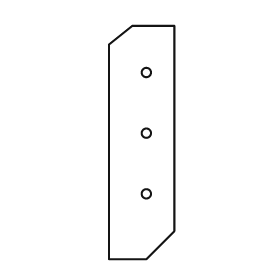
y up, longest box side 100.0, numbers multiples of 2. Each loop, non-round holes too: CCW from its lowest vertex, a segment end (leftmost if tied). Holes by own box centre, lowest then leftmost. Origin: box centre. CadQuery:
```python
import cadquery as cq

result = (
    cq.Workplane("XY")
    .moveTo(-14.0, -50.0)
    .lineTo(2.0, -50.0)
    .lineTo(14.0, -38.0)
    .lineTo(14.0, 50.0)
    .lineTo(-4.0, 50.0)
    .lineTo(-14.0, 42.0)
    .close()
    .moveTo(2.0, -22.0)
    .circle(2.0)
    .moveTo(2.0, 4.0)
    .circle(2.0)
    .moveTo(2.0, 30.0)
    .circle(2.0)
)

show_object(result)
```